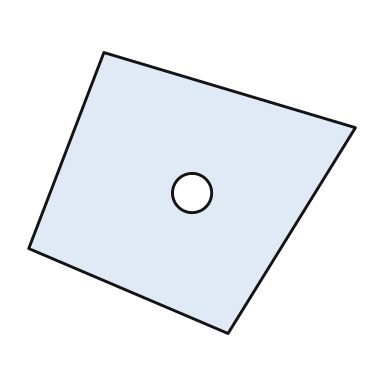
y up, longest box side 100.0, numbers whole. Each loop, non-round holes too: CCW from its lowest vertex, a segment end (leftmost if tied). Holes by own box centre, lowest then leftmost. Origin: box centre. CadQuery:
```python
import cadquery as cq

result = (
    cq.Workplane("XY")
    .moveTo(11.0, -43.0)
    .lineTo(50.0, 20.0)
    .lineTo(-27.0, 43.0)
    .lineTo(-50.0, -17.0)
    .close()
    .moveTo(0.0, 0.0)
    .circle(6.0)
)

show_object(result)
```